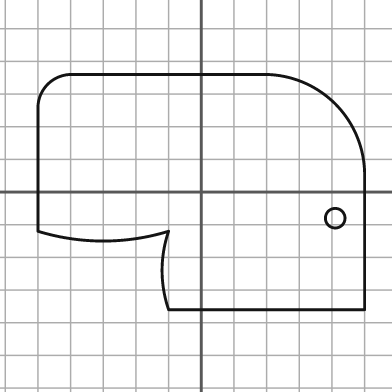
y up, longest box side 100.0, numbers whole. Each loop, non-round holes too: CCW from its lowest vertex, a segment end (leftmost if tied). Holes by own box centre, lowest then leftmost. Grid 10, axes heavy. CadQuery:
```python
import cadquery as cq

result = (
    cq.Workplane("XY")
    .moveTo(-10.0, -36.0)
    .lineTo(50.0, -36.0)
    .lineTo(50.0, 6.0)
    .threePointArc((41.0, 27.0), (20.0, 36.0))
    .lineTo(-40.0, 36.0)
    .threePointArc((-47.0, 33.0), (-50.0, 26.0))
    .lineTo(-50.0, -12.0)
    .threePointArc((-30.0, -15.0), (-10.0, -12.0))
    .threePointArc((-12.0, -24.0), (-10.0, -36.0))
    .close()
    .moveTo(41.0, -8.0)
    .circle(3.0)
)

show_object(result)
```